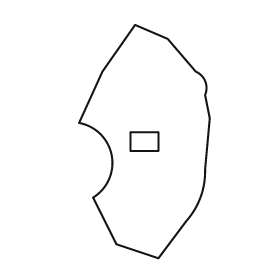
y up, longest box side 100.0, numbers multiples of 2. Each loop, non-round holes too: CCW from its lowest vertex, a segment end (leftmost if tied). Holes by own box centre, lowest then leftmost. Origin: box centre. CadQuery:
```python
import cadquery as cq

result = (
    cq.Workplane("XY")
    .moveTo(6.0, -50.0)
    .lineTo(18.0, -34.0)
    .threePointArc((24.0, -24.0), (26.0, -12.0))
    .lineTo(28.0, 10.0)
    .lineTo(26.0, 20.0)
    .threePointArc((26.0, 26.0), (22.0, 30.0))
    .lineTo(10.0, 44.0)
    .lineTo(-4.0, 50.0)
    .lineTo(-18.0, 30.0)
    .lineTo(-28.0, 8.0)
    .threePointArc((-14.0, -6.0), (-22.0, -24.0))
    .lineTo(-12.0, -44.0)
    .close()
    .moveTo(-6.0, -4.0)
    .lineTo(6.0, -4.0)
    .lineTo(6.0, 4.0)
    .lineTo(-6.0, 4.0)
    .close()
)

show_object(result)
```